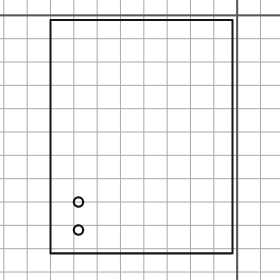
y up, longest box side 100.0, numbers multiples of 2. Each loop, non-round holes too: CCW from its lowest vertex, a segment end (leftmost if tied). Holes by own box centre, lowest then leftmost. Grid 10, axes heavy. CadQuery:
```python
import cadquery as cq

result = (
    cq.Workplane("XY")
    .moveTo(-80.0, -102.0)
    .lineTo(-2.0, -102.0)
    .lineTo(-2.0, -2.0)
    .lineTo(-80.0, -2.0)
    .close()
    .moveTo(-68.0, -92.0)
    .circle(2.0)
    .moveTo(-68.0, -80.0)
    .circle(2.0)
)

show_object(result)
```